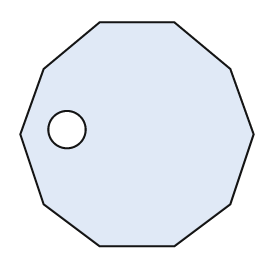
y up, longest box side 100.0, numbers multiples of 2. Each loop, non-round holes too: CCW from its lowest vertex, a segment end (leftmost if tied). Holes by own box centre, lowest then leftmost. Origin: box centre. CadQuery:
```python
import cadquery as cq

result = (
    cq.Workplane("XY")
    .moveTo(-16.0, -48.0)
    .lineTo(16.0, -48.0)
    .lineTo(40.0, -30.0)
    .lineTo(50.0, 0.0)
    .lineTo(40.0, 28.0)
    .lineTo(16.0, 48.0)
    .lineTo(-16.0, 48.0)
    .lineTo(-40.0, 28.0)
    .lineTo(-50.0, 0.0)
    .lineTo(-40.0, -30.0)
    .close()
    .moveTo(-30.0, 2.0)
    .circle(8.0)
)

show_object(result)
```